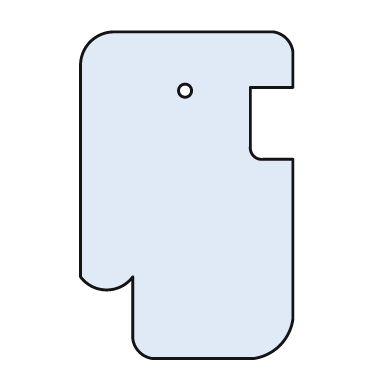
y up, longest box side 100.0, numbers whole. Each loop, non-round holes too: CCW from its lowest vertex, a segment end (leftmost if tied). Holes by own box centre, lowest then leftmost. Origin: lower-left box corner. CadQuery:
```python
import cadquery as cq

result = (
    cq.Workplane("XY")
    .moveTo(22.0, 0.0)
    .lineTo(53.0, 0.0)
    .threePointArc((61.0, 4.0), (65.0, 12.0))
    .lineTo(65.0, 61.0)
    .lineTo(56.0, 61.0)
    .threePointArc((53.0, 62.0), (52.0, 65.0))
    .lineTo(52.0, 83.0)
    .lineTo(65.0, 83.0)
    .lineTo(65.0, 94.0)
    .threePointArc((63.0, 98.0), (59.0, 100.0))
    .lineTo(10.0, 100.0)
    .threePointArc((3.0, 97.0), (0.0, 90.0))
    .lineTo(0.0, 25.0)
    .threePointArc((8.0, 21.0), (16.0, 25.0))
    .lineTo(16.0, 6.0)
    .threePointArc((18.0, 2.0), (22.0, 0.0))
    .close()
    .moveTo(32.0, 82.0)
    .circle(2.0)
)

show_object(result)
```